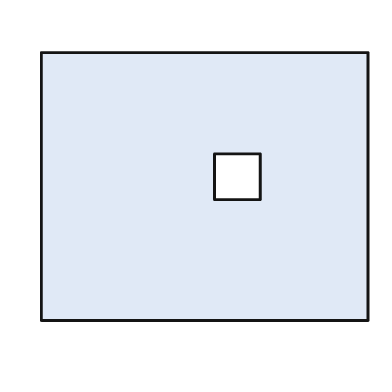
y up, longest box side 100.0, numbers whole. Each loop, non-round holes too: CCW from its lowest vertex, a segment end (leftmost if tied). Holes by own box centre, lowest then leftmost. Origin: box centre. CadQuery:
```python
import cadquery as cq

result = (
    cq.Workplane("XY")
    .moveTo(-50.0, -41.0)
    .lineTo(50.0, -41.0)
    .lineTo(50.0, 41.0)
    .lineTo(-50.0, 41.0)
    .close()
    .moveTo(3.0, -4.0)
    .lineTo(17.0, -4.0)
    .lineTo(17.0, 10.0)
    .lineTo(3.0, 10.0)
    .close()
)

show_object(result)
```